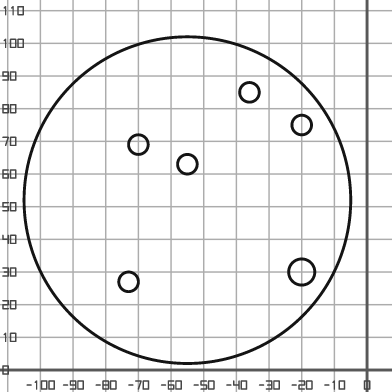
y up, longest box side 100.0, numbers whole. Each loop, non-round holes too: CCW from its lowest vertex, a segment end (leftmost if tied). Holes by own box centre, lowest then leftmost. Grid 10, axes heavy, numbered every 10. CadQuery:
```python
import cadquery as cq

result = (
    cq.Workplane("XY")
    .moveTo(-55.0, 52.0)
    .circle(50.0)
    .moveTo(-73.0, 27.0)
    .circle(3.0)
    .moveTo(-20.0, 30.0)
    .circle(4.0)
    .moveTo(-55.0, 63.0)
    .circle(3.0)
    .moveTo(-70.0, 69.0)
    .circle(3.0)
    .moveTo(-20.0, 75.0)
    .circle(3.0)
    .moveTo(-36.0, 85.0)
    .circle(3.0)
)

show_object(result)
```